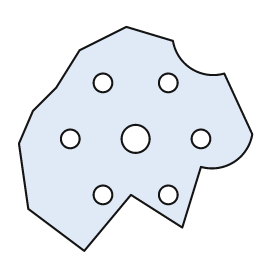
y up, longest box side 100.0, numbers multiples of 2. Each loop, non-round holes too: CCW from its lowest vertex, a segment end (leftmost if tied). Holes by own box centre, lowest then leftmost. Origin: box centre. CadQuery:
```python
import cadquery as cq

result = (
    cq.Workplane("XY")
    .moveTo(-22.0, -48.0)
    .lineTo(-2.0, -24.0)
    .lineTo(20.0, -38.0)
    .lineTo(28.0, -12.0)
    .threePointArc((42.0, -10.0), (50.0, 2.0))
    .lineTo(38.0, 28.0)
    .threePointArc((24.0, 30.0), (16.0, 42.0))
    .lineTo(-4.0, 48.0)
    .lineTo(-24.0, 38.0)
    .lineTo(-34.0, 22.0)
    .lineTo(-44.0, 12.0)
    .lineTo(-50.0, -2.0)
    .lineTo(-46.0, -30.0)
    .close()
    .moveTo(-14.0, -24.0)
    .circle(4.0)
    .moveTo(14.0, -24.0)
    .circle(4.0)
    .moveTo(-28.0, 0.0)
    .circle(4.0)
    .moveTo(0.0, 0.0)
    .circle(6.0)
    .moveTo(28.0, 0.0)
    .circle(4.0)
    .moveTo(-14.0, 24.0)
    .circle(4.0)
    .moveTo(14.0, 24.0)
    .circle(4.0)
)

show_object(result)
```